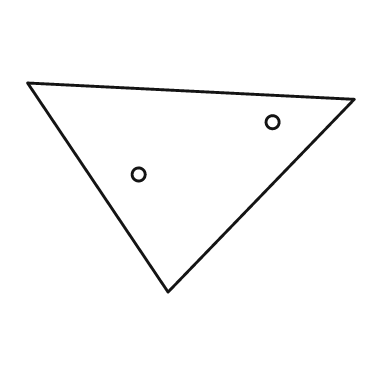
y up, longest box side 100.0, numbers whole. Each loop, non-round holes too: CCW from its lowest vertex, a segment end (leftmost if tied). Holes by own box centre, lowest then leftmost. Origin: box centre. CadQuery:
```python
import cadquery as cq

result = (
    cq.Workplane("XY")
    .moveTo(-7.0, -32.0)
    .lineTo(50.0, 27.0)
    .lineTo(-50.0, 32.0)
    .close()
    .moveTo(-16.0, 4.0)
    .circle(2.0)
    .moveTo(25.0, 20.0)
    .circle(2.0)
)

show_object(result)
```